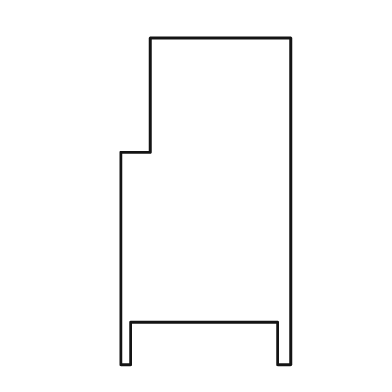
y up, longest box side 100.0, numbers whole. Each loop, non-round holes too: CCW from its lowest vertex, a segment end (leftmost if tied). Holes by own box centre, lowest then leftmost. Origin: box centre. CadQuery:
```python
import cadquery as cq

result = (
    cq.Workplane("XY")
    .moveTo(-26.0, -50.0)
    .lineTo(-23.0, -50.0)
    .lineTo(-23.0, -37.0)
    .lineTo(22.0, -37.0)
    .lineTo(22.0, -50.0)
    .lineTo(26.0, -50.0)
    .lineTo(26.0, 50.0)
    .lineTo(-17.0, 50.0)
    .lineTo(-17.0, 15.0)
    .lineTo(-26.0, 15.0)
    .close()
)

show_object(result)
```